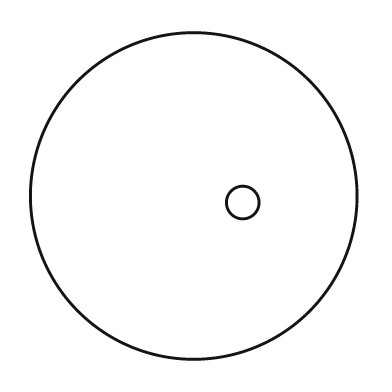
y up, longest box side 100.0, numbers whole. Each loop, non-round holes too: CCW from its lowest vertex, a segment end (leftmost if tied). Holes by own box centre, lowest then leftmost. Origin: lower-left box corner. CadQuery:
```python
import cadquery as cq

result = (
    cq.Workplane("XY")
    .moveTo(50.0, 50.0)
    .circle(50.0)
    .moveTo(65.0, 48.0)
    .circle(5.0)
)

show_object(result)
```